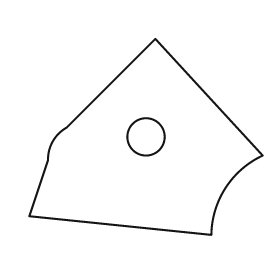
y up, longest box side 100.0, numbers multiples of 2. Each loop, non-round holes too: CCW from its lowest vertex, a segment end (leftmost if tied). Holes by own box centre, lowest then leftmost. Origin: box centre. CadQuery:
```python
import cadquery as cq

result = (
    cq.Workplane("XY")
    .moveTo(28.0, -42.0)
    .threePointArc((34.0, -22.0), (50.0, -8.0))
    .lineTo(4.0, 42.0)
    .lineTo(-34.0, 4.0)
    .threePointArc((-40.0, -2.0), (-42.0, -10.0))
    .lineTo(-50.0, -34.0)
    .close()
    .moveTo(0.0, 0.0)
    .circle(8.0)
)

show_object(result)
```